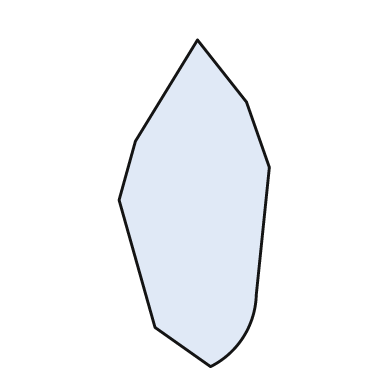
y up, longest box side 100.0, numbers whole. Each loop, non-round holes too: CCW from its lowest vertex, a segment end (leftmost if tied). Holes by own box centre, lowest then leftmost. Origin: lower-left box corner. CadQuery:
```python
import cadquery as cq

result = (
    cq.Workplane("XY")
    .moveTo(28.0, 0.0)
    .threePointArc((38.0, 9.0), (42.0, 22.0))
    .lineTo(46.0, 61.0)
    .lineTo(39.0, 81.0)
    .lineTo(24.0, 100.0)
    .lineTo(5.0, 69.0)
    .lineTo(0.0, 51.0)
    .lineTo(11.0, 12.0)
    .close()
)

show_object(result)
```